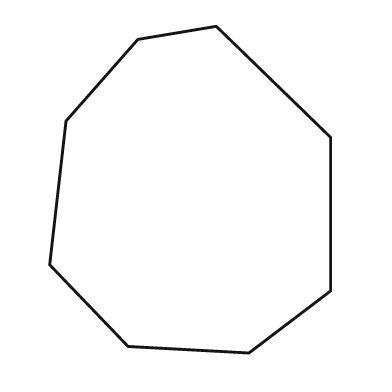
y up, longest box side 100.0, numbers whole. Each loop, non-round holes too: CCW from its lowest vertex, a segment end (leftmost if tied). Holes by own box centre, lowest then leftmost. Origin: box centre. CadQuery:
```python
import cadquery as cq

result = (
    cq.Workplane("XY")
    .moveTo(18.0, -50.0)
    .lineTo(43.0, -31.0)
    .lineTo(43.0, 16.0)
    .lineTo(8.0, 50.0)
    .lineTo(-16.0, 46.0)
    .lineTo(-38.0, 21.0)
    .lineTo(-43.0, -23.0)
    .lineTo(-19.0, -48.0)
    .close()
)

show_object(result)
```